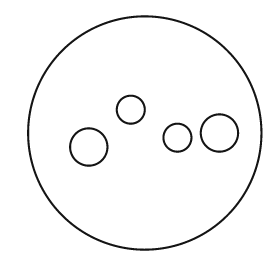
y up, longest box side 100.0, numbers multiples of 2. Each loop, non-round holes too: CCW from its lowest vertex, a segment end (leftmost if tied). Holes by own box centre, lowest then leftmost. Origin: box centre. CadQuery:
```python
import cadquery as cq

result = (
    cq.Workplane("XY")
    .moveTo(0.0, 0.0)
    .circle(50.0)
    .moveTo(-24.0, -6.0)
    .circle(8.0)
    .moveTo(14.0, -2.0)
    .circle(6.0)
    .moveTo(32.0, 0.0)
    .circle(8.0)
    .moveTo(-6.0, 10.0)
    .circle(6.0)
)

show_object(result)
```